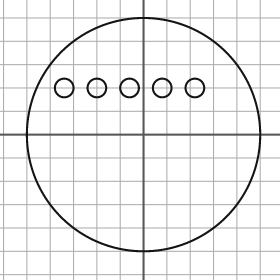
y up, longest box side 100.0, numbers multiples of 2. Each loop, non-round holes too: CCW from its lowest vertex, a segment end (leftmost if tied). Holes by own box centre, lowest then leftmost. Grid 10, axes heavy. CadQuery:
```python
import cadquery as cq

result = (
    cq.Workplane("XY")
    .moveTo(0.0, 0.0)
    .circle(50.0)
    .moveTo(-34.0, 20.0)
    .circle(4.0)
    .moveTo(-20.0, 20.0)
    .circle(4.0)
    .moveTo(-6.0, 20.0)
    .circle(4.0)
    .moveTo(8.0, 20.0)
    .circle(4.0)
    .moveTo(22.0, 20.0)
    .circle(4.0)
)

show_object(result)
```